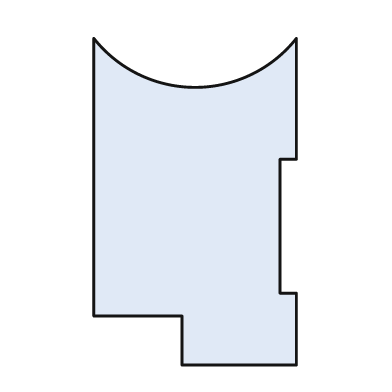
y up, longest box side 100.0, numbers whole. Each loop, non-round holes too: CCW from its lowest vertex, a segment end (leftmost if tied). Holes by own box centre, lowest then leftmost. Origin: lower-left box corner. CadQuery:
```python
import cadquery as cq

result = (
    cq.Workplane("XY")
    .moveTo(27.0, 0.0)
    .lineTo(62.0, 0.0)
    .lineTo(62.0, 22.0)
    .lineTo(57.0, 22.0)
    .lineTo(57.0, 63.0)
    .lineTo(62.0, 63.0)
    .lineTo(62.0, 100.0)
    .threePointArc((31.0, 85.0), (0.0, 100.0))
    .lineTo(0.0, 15.0)
    .lineTo(27.0, 15.0)
    .close()
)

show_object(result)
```